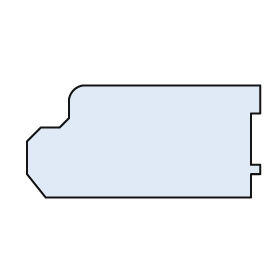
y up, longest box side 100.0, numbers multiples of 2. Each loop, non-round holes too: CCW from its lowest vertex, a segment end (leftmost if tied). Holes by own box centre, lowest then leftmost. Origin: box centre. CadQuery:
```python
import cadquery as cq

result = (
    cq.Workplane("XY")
    .moveTo(-42.0, -24.0)
    .lineTo(46.0, -24.0)
    .lineTo(46.0, -14.0)
    .lineTo(50.0, -14.0)
    .lineTo(50.0, -10.0)
    .lineTo(46.0, -10.0)
    .lineTo(46.0, 12.0)
    .lineTo(50.0, 12.0)
    .lineTo(50.0, 24.0)
    .lineTo(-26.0, 24.0)
    .threePointArc((-30.0, 22.0), (-32.0, 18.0))
    .lineTo(-32.0, 10.0)
    .lineTo(-36.0, 6.0)
    .lineTo(-44.0, 6.0)
    .lineTo(-50.0, 0.0)
    .lineTo(-50.0, -14.0)
    .close()
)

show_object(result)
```